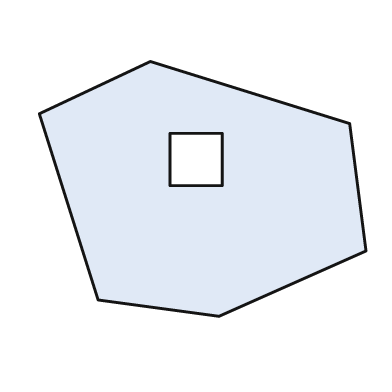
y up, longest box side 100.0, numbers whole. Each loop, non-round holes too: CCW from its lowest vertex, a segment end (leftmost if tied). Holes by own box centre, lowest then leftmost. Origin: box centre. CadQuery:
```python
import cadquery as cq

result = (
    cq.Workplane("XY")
    .moveTo(5.0, -39.0)
    .lineTo(50.0, -19.0)
    .lineTo(45.0, 20.0)
    .lineTo(-16.0, 39.0)
    .lineTo(-50.0, 23.0)
    .lineTo(-32.0, -34.0)
    .close()
    .moveTo(-10.0, 1.0)
    .lineTo(6.0, 1.0)
    .lineTo(6.0, 17.0)
    .lineTo(-10.0, 17.0)
    .close()
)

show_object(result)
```